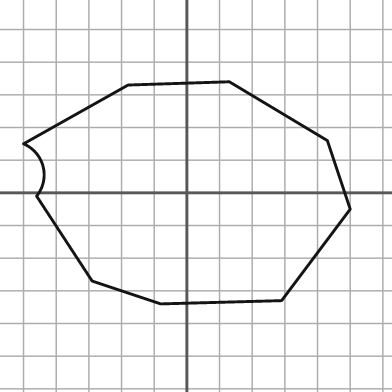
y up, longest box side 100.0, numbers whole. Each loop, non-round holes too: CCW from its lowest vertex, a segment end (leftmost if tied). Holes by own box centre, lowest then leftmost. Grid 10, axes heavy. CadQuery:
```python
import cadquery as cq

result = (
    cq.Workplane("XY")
    .moveTo(-8.0, -34.0)
    .lineTo(29.0, -33.0)
    .lineTo(50.0, -5.0)
    .lineTo(43.0, 16.0)
    .lineTo(13.0, 34.0)
    .lineTo(-18.0, 33.0)
    .lineTo(-50.0, 15.0)
    .threePointArc((-44.0, 8.0), (-46.0, -1.0))
    .lineTo(-29.0, -27.0)
    .close()
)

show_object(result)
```